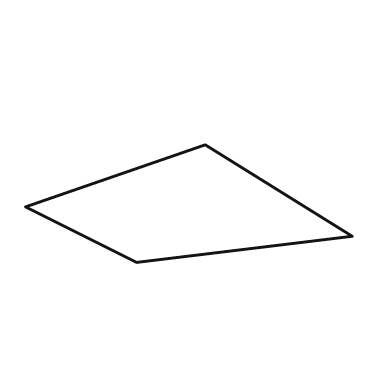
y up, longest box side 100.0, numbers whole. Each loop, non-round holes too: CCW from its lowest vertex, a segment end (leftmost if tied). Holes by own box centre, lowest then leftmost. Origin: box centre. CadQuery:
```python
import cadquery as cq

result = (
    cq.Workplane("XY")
    .moveTo(-16.0, -18.0)
    .lineTo(50.0, -10.0)
    .lineTo(5.0, 18.0)
    .lineTo(-50.0, -1.0)
    .close()
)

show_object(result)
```